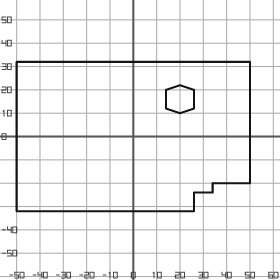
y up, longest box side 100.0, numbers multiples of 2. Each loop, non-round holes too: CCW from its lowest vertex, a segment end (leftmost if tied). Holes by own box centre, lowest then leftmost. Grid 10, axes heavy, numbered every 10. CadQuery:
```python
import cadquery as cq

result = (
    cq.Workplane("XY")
    .moveTo(-50.0, -32.0)
    .lineTo(26.0, -32.0)
    .lineTo(26.0, -24.0)
    .lineTo(34.0, -24.0)
    .lineTo(34.0, -20.0)
    .lineTo(50.0, -20.0)
    .lineTo(50.0, 32.0)
    .lineTo(-50.0, 32.0)
    .close()
    .moveTo(20.0, 10.0)
    .lineTo(26.0, 12.0)
    .lineTo(26.0, 20.0)
    .lineTo(20.0, 22.0)
    .lineTo(14.0, 20.0)
    .lineTo(14.0, 12.0)
    .close()
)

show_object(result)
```